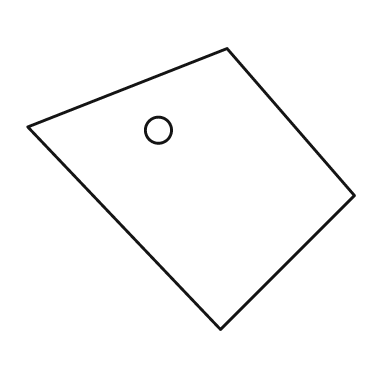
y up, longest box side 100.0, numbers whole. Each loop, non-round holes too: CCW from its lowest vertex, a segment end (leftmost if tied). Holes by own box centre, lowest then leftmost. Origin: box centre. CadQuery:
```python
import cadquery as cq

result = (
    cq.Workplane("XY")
    .moveTo(9.0, -43.0)
    .lineTo(50.0, -2.0)
    .lineTo(11.0, 43.0)
    .lineTo(-50.0, 19.0)
    .close()
    .moveTo(-10.0, 18.0)
    .circle(4.0)
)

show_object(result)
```